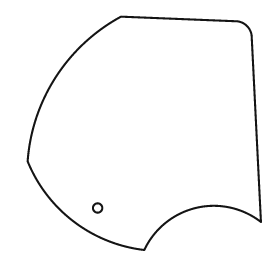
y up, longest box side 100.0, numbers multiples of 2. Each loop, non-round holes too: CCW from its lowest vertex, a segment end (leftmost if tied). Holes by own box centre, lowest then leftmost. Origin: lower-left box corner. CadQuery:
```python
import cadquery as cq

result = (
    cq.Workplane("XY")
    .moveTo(50.0, 0.0)
    .threePointArc((72.0, 18.0), (100.0, 12.0))
    .lineTo(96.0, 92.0)
    .threePointArc((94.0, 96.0), (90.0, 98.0))
    .lineTo(40.0, 100.0)
    .threePointArc((12.0, 74.0), (0.0, 38.0))
    .threePointArc((20.0, 12.0), (50.0, 0.0))
    .close()
    .moveTo(30.0, 18.0)
    .circle(2.0)
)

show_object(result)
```